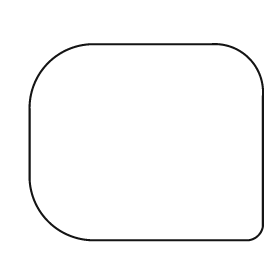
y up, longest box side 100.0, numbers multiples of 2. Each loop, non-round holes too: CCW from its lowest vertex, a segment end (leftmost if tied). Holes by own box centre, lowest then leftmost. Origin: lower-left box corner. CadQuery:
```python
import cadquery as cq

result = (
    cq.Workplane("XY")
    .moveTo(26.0, 0.0)
    .lineTo(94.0, 0.0)
    .threePointArc((98.0, 2.0), (100.0, 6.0))
    .lineTo(100.0, 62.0)
    .threePointArc((94.0, 78.0), (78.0, 84.0))
    .lineTo(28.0, 84.0)
    .threePointArc((8.0, 76.0), (0.0, 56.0))
    .lineTo(0.0, 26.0)
    .threePointArc((8.0, 8.0), (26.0, 0.0))
    .close()
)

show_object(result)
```